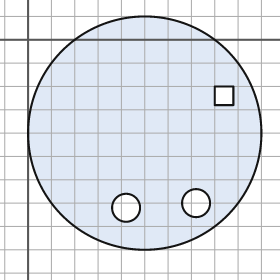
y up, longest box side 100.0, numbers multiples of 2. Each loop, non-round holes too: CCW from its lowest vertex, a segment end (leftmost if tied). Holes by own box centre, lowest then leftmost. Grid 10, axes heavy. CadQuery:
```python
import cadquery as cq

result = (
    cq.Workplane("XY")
    .moveTo(50.0, -40.0)
    .circle(50.0)
    .moveTo(42.0, -72.0)
    .circle(6.0)
    .moveTo(72.0, -70.0)
    .circle(6.0)
    .moveTo(80.0, -28.0)
    .lineTo(88.0, -28.0)
    .lineTo(88.0, -20.0)
    .lineTo(80.0, -20.0)
    .close()
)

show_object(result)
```